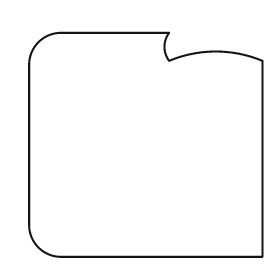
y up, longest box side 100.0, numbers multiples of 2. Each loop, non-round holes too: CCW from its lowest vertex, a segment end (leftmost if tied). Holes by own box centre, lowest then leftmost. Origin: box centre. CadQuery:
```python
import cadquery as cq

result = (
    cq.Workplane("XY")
    .moveTo(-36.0, -48.0)
    .lineTo(50.0, -48.0)
    .lineTo(50.0, 36.0)
    .threePointArc((30.0, 40.0), (10.0, 36.0))
    .threePointArc((8.0, 42.0), (10.0, 48.0))
    .lineTo(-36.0, 48.0)
    .threePointArc((-46.0, 44.0), (-50.0, 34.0))
    .lineTo(-50.0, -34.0)
    .threePointArc((-46.0, -44.0), (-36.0, -48.0))
    .close()
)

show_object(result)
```